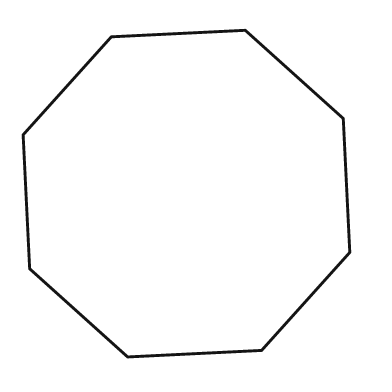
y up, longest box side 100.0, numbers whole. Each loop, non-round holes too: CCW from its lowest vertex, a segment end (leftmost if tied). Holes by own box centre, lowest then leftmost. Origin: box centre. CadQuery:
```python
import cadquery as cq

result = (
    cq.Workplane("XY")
    .moveTo(-18.0, -50.0)
    .lineTo(23.0, -48.0)
    .lineTo(50.0, -18.0)
    .lineTo(48.0, 23.0)
    .lineTo(18.0, 50.0)
    .lineTo(-23.0, 48.0)
    .lineTo(-50.0, 18.0)
    .lineTo(-48.0, -23.0)
    .close()
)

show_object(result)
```